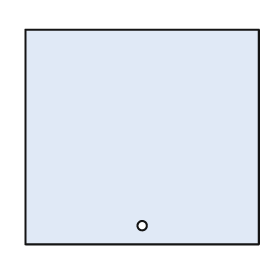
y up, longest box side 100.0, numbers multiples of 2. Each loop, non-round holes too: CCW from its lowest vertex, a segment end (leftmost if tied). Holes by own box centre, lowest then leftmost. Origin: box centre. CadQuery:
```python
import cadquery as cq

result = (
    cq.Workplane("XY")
    .moveTo(-50.0, -46.0)
    .lineTo(50.0, -46.0)
    .lineTo(50.0, 46.0)
    .lineTo(-50.0, 46.0)
    .close()
    .moveTo(0.0, -38.0)
    .circle(2.0)
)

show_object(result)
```